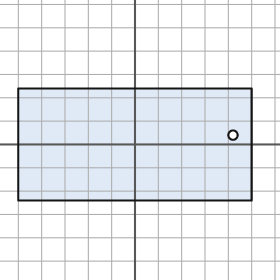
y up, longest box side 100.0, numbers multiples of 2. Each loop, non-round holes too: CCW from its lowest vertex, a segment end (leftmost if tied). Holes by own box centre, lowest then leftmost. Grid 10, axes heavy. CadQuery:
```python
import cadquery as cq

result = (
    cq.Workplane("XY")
    .moveTo(-50.0, -24.0)
    .lineTo(50.0, -24.0)
    .lineTo(50.0, 24.0)
    .lineTo(-50.0, 24.0)
    .close()
    .moveTo(42.0, 4.0)
    .circle(2.0)
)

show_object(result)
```